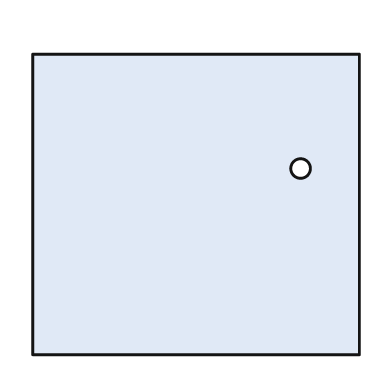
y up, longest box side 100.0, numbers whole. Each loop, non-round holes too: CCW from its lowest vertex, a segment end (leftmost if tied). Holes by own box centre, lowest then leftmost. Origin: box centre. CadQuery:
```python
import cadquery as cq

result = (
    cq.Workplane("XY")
    .moveTo(-50.0, -46.0)
    .lineTo(50.0, -46.0)
    .lineTo(50.0, 46.0)
    .lineTo(-50.0, 46.0)
    .close()
    .moveTo(32.0, 11.0)
    .circle(3.0)
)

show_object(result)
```